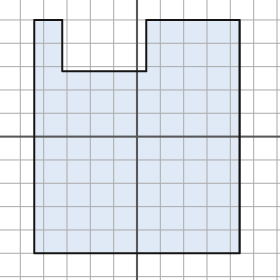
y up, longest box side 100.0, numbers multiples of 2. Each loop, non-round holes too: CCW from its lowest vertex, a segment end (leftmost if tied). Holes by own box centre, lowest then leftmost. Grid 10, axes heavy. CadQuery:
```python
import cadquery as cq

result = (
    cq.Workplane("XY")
    .moveTo(-44.0, -50.0)
    .lineTo(44.0, -50.0)
    .lineTo(44.0, 50.0)
    .lineTo(4.0, 50.0)
    .lineTo(4.0, 28.0)
    .lineTo(-32.0, 28.0)
    .lineTo(-32.0, 50.0)
    .lineTo(-44.0, 50.0)
    .close()
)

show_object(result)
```